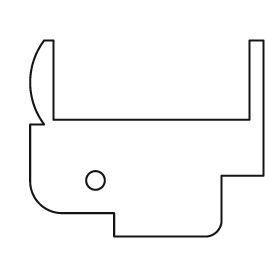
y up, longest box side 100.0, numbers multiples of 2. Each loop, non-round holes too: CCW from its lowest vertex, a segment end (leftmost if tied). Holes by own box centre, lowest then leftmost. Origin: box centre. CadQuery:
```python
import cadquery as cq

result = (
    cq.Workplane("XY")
    .moveTo(-14.0, -42.0)
    .lineTo(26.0, -42.0)
    .threePointArc((30.0, -40.0), (32.0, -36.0))
    .lineTo(32.0, -16.0)
    .lineTo(50.0, -16.0)
    .lineTo(50.0, 42.0)
    .lineTo(44.0, 42.0)
    .lineTo(44.0, 8.0)
    .lineTo(-40.0, 8.0)
    .lineTo(-40.0, 42.0)
    .lineTo(-44.0, 42.0)
    .threePointArc((-50.0, 24.0), (-44.0, 6.0))
    .lineTo(-50.0, 6.0)
    .lineTo(-50.0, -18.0)
    .threePointArc((-46.0, -28.0), (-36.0, -32.0))
    .lineTo(-14.0, -32.0)
    .close()
    .moveTo(-22.0, -18.0)
    .circle(4.0)
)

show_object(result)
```